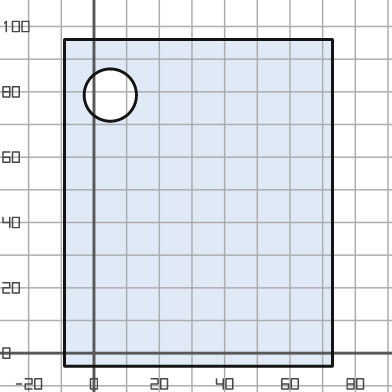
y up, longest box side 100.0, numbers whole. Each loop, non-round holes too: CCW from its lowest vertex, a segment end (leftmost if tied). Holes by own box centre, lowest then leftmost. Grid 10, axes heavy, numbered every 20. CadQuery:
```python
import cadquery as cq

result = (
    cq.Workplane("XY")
    .moveTo(-9.0, -4.0)
    .lineTo(73.0, -4.0)
    .lineTo(73.0, 96.0)
    .lineTo(-9.0, 96.0)
    .close()
    .moveTo(5.0, 79.0)
    .circle(8.0)
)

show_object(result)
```